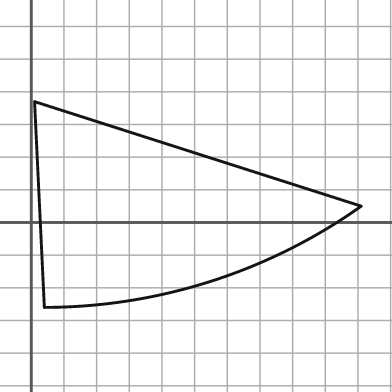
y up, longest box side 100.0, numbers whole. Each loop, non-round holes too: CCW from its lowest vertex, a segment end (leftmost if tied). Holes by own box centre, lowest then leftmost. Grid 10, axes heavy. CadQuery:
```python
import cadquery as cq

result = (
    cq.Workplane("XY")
    .moveTo(4.0, -26.0)
    .threePointArc((55.0, -18.0), (101.0, 5.0))
    .lineTo(1.0, 37.0)
    .close()
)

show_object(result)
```